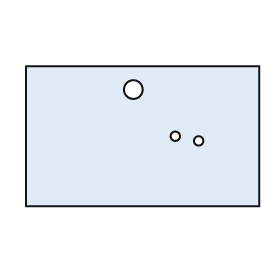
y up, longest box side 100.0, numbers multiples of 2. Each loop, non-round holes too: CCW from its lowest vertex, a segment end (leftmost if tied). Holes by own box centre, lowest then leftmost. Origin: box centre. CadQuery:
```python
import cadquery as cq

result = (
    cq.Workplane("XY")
    .moveTo(-50.0, -30.0)
    .lineTo(50.0, -30.0)
    .lineTo(50.0, 30.0)
    .lineTo(-50.0, 30.0)
    .close()
    .moveTo(24.0, -2.0)
    .circle(2.0)
    .moveTo(14.0, 0.0)
    .circle(2.0)
    .moveTo(-4.0, 20.0)
    .circle(4.0)
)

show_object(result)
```